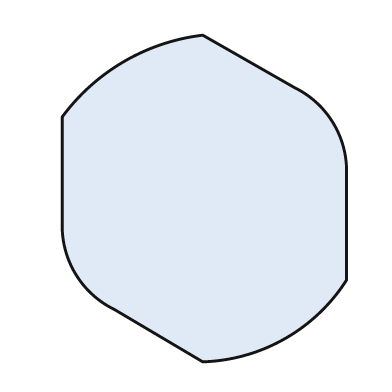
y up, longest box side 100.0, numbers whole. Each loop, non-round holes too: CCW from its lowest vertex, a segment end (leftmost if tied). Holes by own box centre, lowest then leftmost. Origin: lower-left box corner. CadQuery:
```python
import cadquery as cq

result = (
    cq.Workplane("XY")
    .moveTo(43.0, 0.0)
    .threePointArc((68.0, 7.0), (87.0, 25.0))
    .lineTo(87.0, 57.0)
    .threePointArc((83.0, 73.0), (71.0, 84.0))
    .lineTo(43.0, 100.0)
    .threePointArc((19.0, 92.0), (0.0, 75.0))
    .lineTo(0.0, 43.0)
    .threePointArc((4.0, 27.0), (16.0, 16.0))
    .close()
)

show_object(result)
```